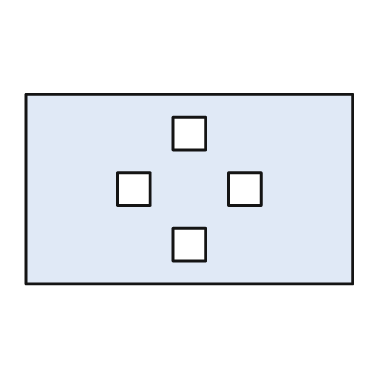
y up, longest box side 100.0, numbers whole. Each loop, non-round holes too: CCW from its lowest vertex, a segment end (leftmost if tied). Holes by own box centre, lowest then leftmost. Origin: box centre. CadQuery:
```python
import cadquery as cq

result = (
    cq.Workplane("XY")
    .moveTo(-50.0, -29.0)
    .lineTo(50.0, -29.0)
    .lineTo(50.0, 29.0)
    .lineTo(-50.0, 29.0)
    .close()
    .moveTo(-5.0, -22.0)
    .lineTo(5.0, -22.0)
    .lineTo(5.0, -12.0)
    .lineTo(-5.0, -12.0)
    .close()
    .moveTo(-22.0, -5.0)
    .lineTo(-12.0, -5.0)
    .lineTo(-12.0, 5.0)
    .lineTo(-22.0, 5.0)
    .close()
    .moveTo(12.0, -5.0)
    .lineTo(22.0, -5.0)
    .lineTo(22.0, 5.0)
    .lineTo(12.0, 5.0)
    .close()
    .moveTo(-5.0, 12.0)
    .lineTo(5.0, 12.0)
    .lineTo(5.0, 22.0)
    .lineTo(-5.0, 22.0)
    .close()
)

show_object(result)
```